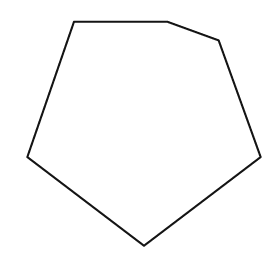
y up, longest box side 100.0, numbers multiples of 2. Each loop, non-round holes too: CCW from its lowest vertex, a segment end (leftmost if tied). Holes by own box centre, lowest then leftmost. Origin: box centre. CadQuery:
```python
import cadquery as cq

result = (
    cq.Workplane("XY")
    .moveTo(0.0, -48.0)
    .lineTo(50.0, -10.0)
    .lineTo(32.0, 40.0)
    .lineTo(10.0, 48.0)
    .lineTo(-30.0, 48.0)
    .lineTo(-50.0, -10.0)
    .close()
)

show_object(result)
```